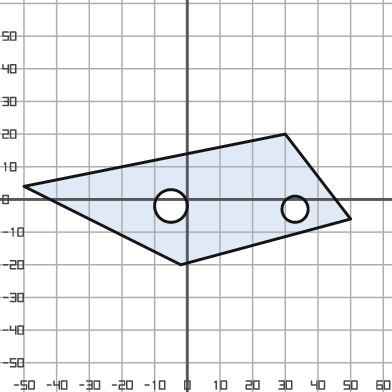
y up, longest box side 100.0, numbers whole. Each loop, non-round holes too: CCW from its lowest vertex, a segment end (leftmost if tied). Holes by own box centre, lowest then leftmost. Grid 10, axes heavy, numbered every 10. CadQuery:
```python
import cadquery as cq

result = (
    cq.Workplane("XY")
    .moveTo(-2.0, -20.0)
    .lineTo(50.0, -6.0)
    .lineTo(30.0, 20.0)
    .lineTo(-50.0, 4.0)
    .close()
    .moveTo(33.0, -3.0)
    .circle(4.0)
    .moveTo(-5.0, -2.0)
    .circle(5.0)
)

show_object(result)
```